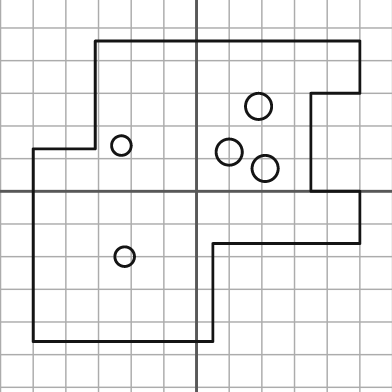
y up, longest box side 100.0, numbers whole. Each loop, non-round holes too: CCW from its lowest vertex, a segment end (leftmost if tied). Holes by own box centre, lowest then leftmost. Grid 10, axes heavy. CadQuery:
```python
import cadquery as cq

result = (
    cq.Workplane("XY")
    .moveTo(-50.0, -46.0)
    .lineTo(5.0, -46.0)
    .lineTo(5.0, -16.0)
    .lineTo(50.0, -16.0)
    .lineTo(50.0, 0.0)
    .lineTo(35.0, 0.0)
    .lineTo(35.0, 30.0)
    .lineTo(50.0, 30.0)
    .lineTo(50.0, 46.0)
    .lineTo(-31.0, 46.0)
    .lineTo(-31.0, 13.0)
    .lineTo(-50.0, 13.0)
    .close()
    .moveTo(-22.0, -20.0)
    .circle(3.0)
    .moveTo(21.0, 7.0)
    .circle(4.0)
    .moveTo(10.0, 12.0)
    .circle(4.0)
    .moveTo(-23.0, 14.0)
    .circle(3.0)
    .moveTo(19.0, 26.0)
    .circle(4.0)
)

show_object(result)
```